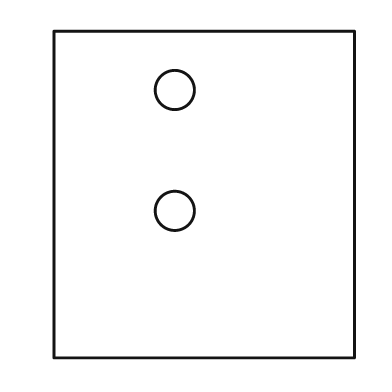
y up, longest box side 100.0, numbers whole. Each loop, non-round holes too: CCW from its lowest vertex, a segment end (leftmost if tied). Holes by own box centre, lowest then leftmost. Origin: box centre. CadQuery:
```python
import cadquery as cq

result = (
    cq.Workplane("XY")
    .moveTo(-46.0, -50.0)
    .lineTo(46.0, -50.0)
    .lineTo(46.0, 50.0)
    .lineTo(-46.0, 50.0)
    .close()
    .moveTo(-9.0, -5.0)
    .circle(6.0)
    .moveTo(-9.0, 32.0)
    .circle(6.0)
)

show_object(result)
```